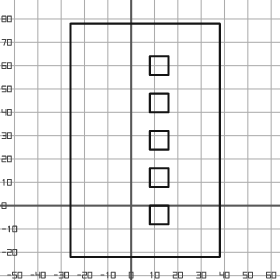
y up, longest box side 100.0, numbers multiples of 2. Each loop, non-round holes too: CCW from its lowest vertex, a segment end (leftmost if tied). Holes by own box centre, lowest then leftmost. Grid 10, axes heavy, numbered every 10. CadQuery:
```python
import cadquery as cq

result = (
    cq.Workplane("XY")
    .moveTo(-26.0, -22.0)
    .lineTo(38.0, -22.0)
    .lineTo(38.0, 78.0)
    .lineTo(-26.0, 78.0)
    .close()
    .moveTo(8.0, -8.0)
    .lineTo(16.0, -8.0)
    .lineTo(16.0, 0.0)
    .lineTo(8.0, 0.0)
    .close()
    .moveTo(8.0, 8.0)
    .lineTo(16.0, 8.0)
    .lineTo(16.0, 16.0)
    .lineTo(8.0, 16.0)
    .close()
    .moveTo(8.0, 24.0)
    .lineTo(16.0, 24.0)
    .lineTo(16.0, 32.0)
    .lineTo(8.0, 32.0)
    .close()
    .moveTo(8.0, 40.0)
    .lineTo(16.0, 40.0)
    .lineTo(16.0, 48.0)
    .lineTo(8.0, 48.0)
    .close()
    .moveTo(8.0, 56.0)
    .lineTo(16.0, 56.0)
    .lineTo(16.0, 64.0)
    .lineTo(8.0, 64.0)
    .close()
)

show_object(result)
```